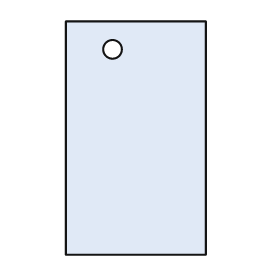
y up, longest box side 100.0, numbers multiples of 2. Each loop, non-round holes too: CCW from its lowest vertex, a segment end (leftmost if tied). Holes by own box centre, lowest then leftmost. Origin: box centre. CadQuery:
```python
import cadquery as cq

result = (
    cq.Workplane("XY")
    .moveTo(-30.0, -50.0)
    .lineTo(30.0, -50.0)
    .lineTo(30.0, 50.0)
    .lineTo(-30.0, 50.0)
    .close()
    .moveTo(-10.0, 38.0)
    .circle(4.0)
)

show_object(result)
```